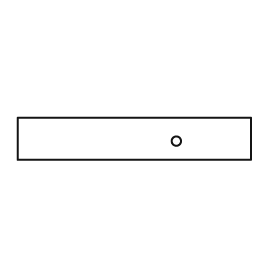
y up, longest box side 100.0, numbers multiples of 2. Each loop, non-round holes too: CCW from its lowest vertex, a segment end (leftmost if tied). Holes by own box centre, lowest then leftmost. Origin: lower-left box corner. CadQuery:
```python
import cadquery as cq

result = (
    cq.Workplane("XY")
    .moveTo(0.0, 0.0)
    .lineTo(100.0, 0.0)
    .lineTo(100.0, 18.0)
    .lineTo(0.0, 18.0)
    .close()
    .moveTo(68.0, 8.0)
    .circle(2.0)
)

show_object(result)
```